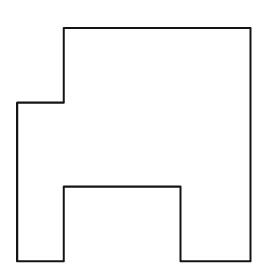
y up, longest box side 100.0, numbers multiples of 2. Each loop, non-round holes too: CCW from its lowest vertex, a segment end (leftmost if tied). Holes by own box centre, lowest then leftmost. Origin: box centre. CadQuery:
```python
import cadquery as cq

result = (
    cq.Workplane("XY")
    .moveTo(-50.0, -50.0)
    .lineTo(-30.0, -50.0)
    .lineTo(-30.0, -18.0)
    .lineTo(20.0, -18.0)
    .lineTo(20.0, -50.0)
    .lineTo(50.0, -50.0)
    .lineTo(50.0, 50.0)
    .lineTo(-30.0, 50.0)
    .lineTo(-30.0, 18.0)
    .lineTo(-50.0, 18.0)
    .close()
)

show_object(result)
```